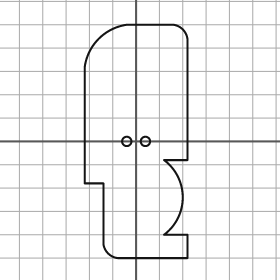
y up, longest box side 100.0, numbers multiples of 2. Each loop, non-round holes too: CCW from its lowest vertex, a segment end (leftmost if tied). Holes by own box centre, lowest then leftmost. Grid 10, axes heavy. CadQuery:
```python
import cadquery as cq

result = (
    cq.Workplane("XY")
    .moveTo(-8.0, -50.0)
    .lineTo(22.0, -50.0)
    .lineTo(22.0, -40.0)
    .lineTo(12.0, -40.0)
    .threePointArc((20.0, -24.0), (12.0, -8.0))
    .lineTo(22.0, -8.0)
    .lineTo(22.0, 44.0)
    .threePointArc((20.0, 48.0), (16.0, 50.0))
    .lineTo(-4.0, 50.0)
    .threePointArc((-16.0, 44.0), (-22.0, 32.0))
    .lineTo(-22.0, -18.0)
    .lineTo(-14.0, -18.0)
    .lineTo(-14.0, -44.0)
    .threePointArc((-12.0, -48.0), (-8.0, -50.0))
    .close()
    .moveTo(-4.0, 0.0)
    .circle(2.0)
    .moveTo(4.0, 0.0)
    .circle(2.0)
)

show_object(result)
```